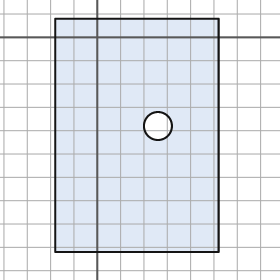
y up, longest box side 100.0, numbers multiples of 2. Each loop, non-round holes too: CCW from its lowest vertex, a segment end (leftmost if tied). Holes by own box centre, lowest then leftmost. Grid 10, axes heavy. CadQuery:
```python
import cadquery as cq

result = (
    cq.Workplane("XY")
    .moveTo(-18.0, -92.0)
    .lineTo(52.0, -92.0)
    .lineTo(52.0, 8.0)
    .lineTo(-18.0, 8.0)
    .close()
    .moveTo(26.0, -38.0)
    .circle(6.0)
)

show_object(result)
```